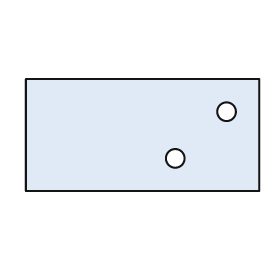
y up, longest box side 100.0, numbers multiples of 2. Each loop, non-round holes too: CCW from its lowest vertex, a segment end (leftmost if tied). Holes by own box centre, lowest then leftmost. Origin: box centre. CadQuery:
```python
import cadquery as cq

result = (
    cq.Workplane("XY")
    .moveTo(-50.0, -24.0)
    .lineTo(50.0, -24.0)
    .lineTo(50.0, 24.0)
    .lineTo(-50.0, 24.0)
    .close()
    .moveTo(14.0, -10.0)
    .circle(4.0)
    .moveTo(36.0, 10.0)
    .circle(4.0)
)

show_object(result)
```